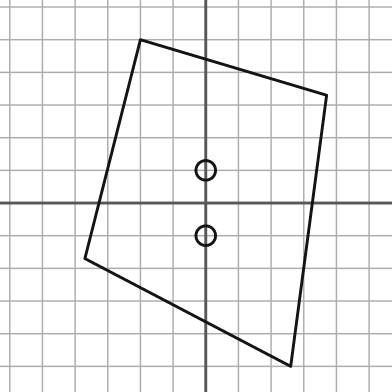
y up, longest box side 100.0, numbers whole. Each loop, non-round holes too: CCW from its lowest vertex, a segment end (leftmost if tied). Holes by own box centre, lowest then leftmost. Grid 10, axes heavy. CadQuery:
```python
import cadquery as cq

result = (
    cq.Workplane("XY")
    .moveTo(26.0, -50.0)
    .lineTo(37.0, 33.0)
    .lineTo(-20.0, 50.0)
    .lineTo(-37.0, -17.0)
    .close()
    .moveTo(0.0, -10.0)
    .circle(3.0)
    .moveTo(0.0, 10.0)
    .circle(3.0)
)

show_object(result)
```